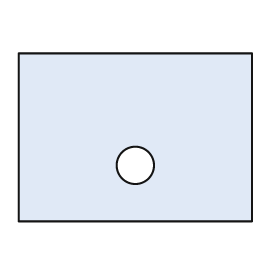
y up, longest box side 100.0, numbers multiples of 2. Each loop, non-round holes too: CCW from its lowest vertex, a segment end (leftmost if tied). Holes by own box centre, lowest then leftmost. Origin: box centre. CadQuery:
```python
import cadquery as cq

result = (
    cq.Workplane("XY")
    .moveTo(-50.0, -36.0)
    .lineTo(50.0, -36.0)
    .lineTo(50.0, 36.0)
    .lineTo(-50.0, 36.0)
    .close()
    .moveTo(0.0, -12.0)
    .circle(8.0)
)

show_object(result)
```